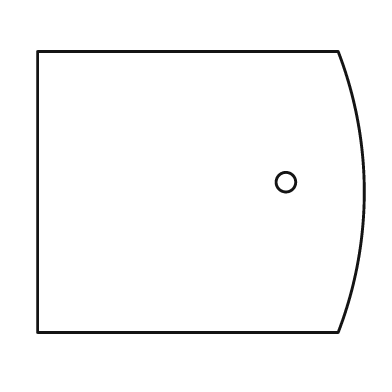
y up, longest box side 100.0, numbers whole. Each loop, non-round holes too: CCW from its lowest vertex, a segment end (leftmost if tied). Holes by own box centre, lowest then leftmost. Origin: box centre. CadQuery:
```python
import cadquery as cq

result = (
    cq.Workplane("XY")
    .moveTo(-50.0, -43.0)
    .lineTo(42.0, -43.0)
    .threePointArc((50.0, 0.0), (42.0, 43.0))
    .lineTo(-50.0, 43.0)
    .close()
    .moveTo(26.0, 3.0)
    .circle(3.0)
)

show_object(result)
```